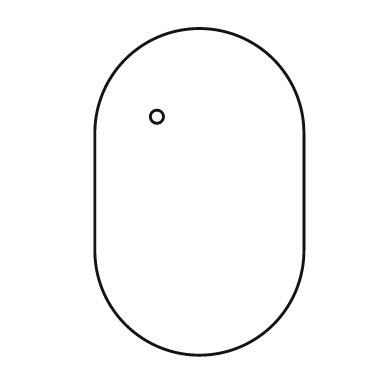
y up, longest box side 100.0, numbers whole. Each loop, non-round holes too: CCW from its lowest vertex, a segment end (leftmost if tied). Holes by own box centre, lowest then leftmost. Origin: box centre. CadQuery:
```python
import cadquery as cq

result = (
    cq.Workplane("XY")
    .moveTo(-32.0, -18.0)
    .threePointArc((0.0, -50.0), (32.0, -18.0))
    .lineTo(32.0, 18.0)
    .threePointArc((0.0, 50.0), (-32.0, 18.0))
    .close()
    .moveTo(-13.0, 23.0)
    .circle(2.0)
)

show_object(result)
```